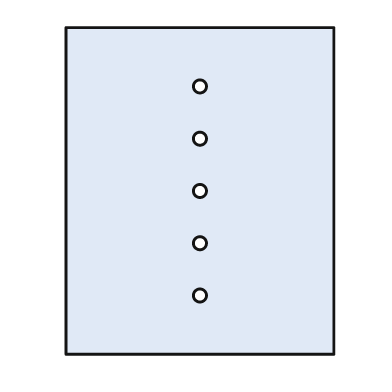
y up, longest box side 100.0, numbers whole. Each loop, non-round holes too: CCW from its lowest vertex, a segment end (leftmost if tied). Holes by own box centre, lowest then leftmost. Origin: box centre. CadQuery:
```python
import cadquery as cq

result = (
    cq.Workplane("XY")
    .moveTo(-41.0, -50.0)
    .lineTo(41.0, -50.0)
    .lineTo(41.0, 50.0)
    .lineTo(-41.0, 50.0)
    .close()
    .moveTo(0.0, -32.0)
    .circle(2.0)
    .moveTo(0.0, -16.0)
    .circle(2.0)
    .moveTo(0.0, 0.0)
    .circle(2.0)
    .moveTo(0.0, 16.0)
    .circle(2.0)
    .moveTo(0.0, 32.0)
    .circle(2.0)
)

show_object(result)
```